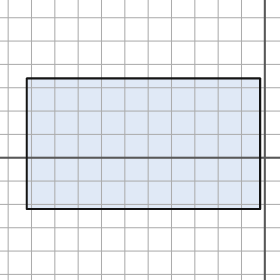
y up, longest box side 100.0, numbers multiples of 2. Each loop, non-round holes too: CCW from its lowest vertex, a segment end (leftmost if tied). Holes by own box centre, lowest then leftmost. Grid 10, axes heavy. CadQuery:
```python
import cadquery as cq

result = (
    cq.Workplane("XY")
    .moveTo(-102.0, -22.0)
    .lineTo(-2.0, -22.0)
    .lineTo(-2.0, 34.0)
    .lineTo(-102.0, 34.0)
    .close()
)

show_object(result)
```